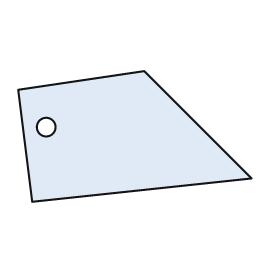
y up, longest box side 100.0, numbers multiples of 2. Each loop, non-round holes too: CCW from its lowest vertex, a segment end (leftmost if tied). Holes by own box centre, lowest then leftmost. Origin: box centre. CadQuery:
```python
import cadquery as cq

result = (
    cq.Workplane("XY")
    .moveTo(-44.0, -28.0)
    .lineTo(50.0, -18.0)
    .lineTo(4.0, 28.0)
    .lineTo(-50.0, 20.0)
    .close()
    .moveTo(-38.0, 4.0)
    .circle(4.0)
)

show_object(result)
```